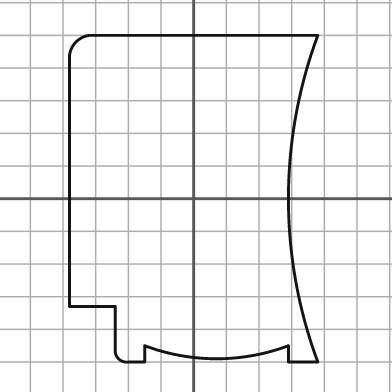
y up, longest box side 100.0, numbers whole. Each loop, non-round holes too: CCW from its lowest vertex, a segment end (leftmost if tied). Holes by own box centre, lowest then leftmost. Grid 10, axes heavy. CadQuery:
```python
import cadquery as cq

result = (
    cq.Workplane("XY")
    .moveTo(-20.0, -50.0)
    .lineTo(-15.0, -50.0)
    .lineTo(-15.0, -45.0)
    .threePointArc((7.0, -49.0), (29.0, -45.0))
    .lineTo(29.0, -50.0)
    .lineTo(38.0, -50.0)
    .threePointArc((29.0, 0.0), (38.0, 50.0))
    .lineTo(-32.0, 50.0)
    .threePointArc((-36.0, 48.0), (-38.0, 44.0))
    .lineTo(-38.0, -33.0)
    .lineTo(-24.0, -33.0)
    .lineTo(-24.0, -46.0)
    .threePointArc((-23.0, -49.0), (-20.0, -50.0))
    .close()
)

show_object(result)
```